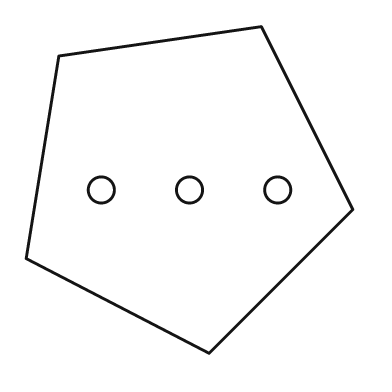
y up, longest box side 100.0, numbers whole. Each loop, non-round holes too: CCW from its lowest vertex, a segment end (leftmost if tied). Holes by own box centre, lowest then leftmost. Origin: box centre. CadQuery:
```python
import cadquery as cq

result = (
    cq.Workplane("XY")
    .moveTo(6.0, -50.0)
    .lineTo(50.0, -6.0)
    .lineTo(22.0, 50.0)
    .lineTo(-40.0, 41.0)
    .lineTo(-50.0, -21.0)
    .close()
    .moveTo(-27.0, 0.0)
    .circle(4.0)
    .moveTo(0.0, 0.0)
    .circle(4.0)
    .moveTo(27.0, 0.0)
    .circle(4.0)
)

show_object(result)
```